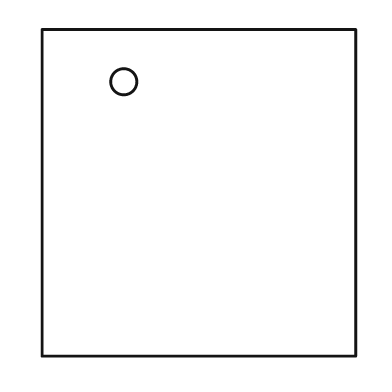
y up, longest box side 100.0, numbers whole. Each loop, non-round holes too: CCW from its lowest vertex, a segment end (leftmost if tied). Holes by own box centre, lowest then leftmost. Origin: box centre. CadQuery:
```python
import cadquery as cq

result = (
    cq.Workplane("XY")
    .moveTo(-48.0, -50.0)
    .lineTo(48.0, -50.0)
    .lineTo(48.0, 50.0)
    .lineTo(-48.0, 50.0)
    .close()
    .moveTo(-23.0, 34.0)
    .circle(4.0)
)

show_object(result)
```